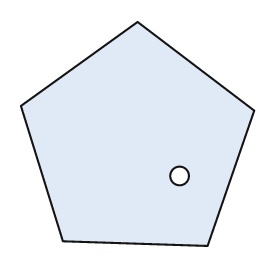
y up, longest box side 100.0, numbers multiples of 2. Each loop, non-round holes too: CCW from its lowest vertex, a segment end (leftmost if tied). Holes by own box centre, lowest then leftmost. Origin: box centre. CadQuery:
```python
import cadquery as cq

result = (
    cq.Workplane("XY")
    .moveTo(30.0, -48.0)
    .lineTo(50.0, 10.0)
    .lineTo(0.0, 48.0)
    .lineTo(-50.0, 12.0)
    .lineTo(-32.0, -46.0)
    .close()
    .moveTo(18.0, -18.0)
    .circle(4.0)
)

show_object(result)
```